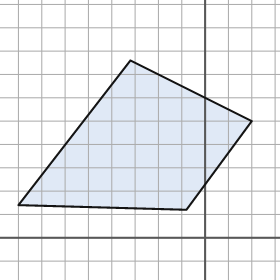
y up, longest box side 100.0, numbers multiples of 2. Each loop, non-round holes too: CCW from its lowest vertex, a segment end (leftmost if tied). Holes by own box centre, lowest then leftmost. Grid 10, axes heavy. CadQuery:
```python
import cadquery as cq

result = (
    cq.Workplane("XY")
    .moveTo(-8.0, 12.0)
    .lineTo(20.0, 50.0)
    .lineTo(-32.0, 76.0)
    .lineTo(-80.0, 14.0)
    .close()
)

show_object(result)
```